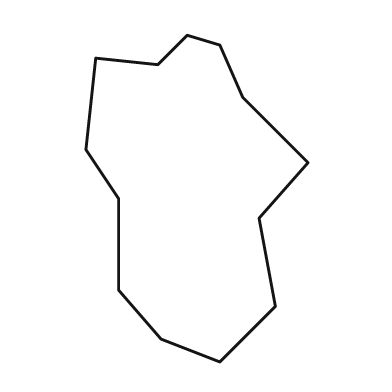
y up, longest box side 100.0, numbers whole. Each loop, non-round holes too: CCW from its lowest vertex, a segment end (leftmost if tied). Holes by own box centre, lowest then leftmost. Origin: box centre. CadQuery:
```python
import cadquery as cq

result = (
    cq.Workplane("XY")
    .moveTo(7.0, -50.0)
    .lineTo(24.0, -33.0)
    .lineTo(19.0, -6.0)
    .lineTo(34.0, 11.0)
    .lineTo(14.0, 31.0)
    .lineTo(7.0, 47.0)
    .lineTo(-3.0, 50.0)
    .lineTo(-12.0, 41.0)
    .lineTo(-31.0, 43.0)
    .lineTo(-34.0, 15.0)
    .lineTo(-24.0, 0.0)
    .lineTo(-24.0, -28.0)
    .lineTo(-11.0, -43.0)
    .close()
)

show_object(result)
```